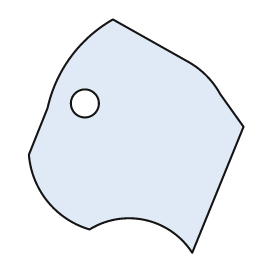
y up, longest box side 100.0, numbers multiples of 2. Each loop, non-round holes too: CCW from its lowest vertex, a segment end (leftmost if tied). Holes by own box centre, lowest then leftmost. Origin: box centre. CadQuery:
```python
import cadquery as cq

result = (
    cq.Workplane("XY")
    .moveTo(24.0, -50.0)
    .lineTo(46.0, 4.0)
    .lineTo(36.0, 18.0)
    .threePointArc((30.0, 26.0), (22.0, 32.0))
    .lineTo(-10.0, 50.0)
    .threePointArc((-28.0, 34.0), (-38.0, 12.0))
    .lineTo(-46.0, -8.0)
    .threePointArc((-38.0, -28.0), (-20.0, -40.0))
    .threePointArc((4.0, -36.0), (24.0, -50.0))
    .close()
    .moveTo(-22.0, 14.0)
    .circle(6.0)
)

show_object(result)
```